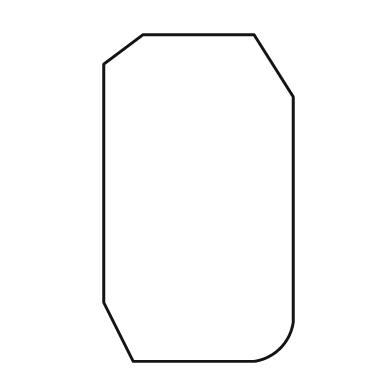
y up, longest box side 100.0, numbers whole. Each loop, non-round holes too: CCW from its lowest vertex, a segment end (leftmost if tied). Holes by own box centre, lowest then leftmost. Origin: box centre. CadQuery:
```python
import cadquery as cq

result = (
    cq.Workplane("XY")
    .moveTo(-20.0, -50.0)
    .lineTo(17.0, -50.0)
    .threePointArc((25.0, -46.0), (29.0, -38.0))
    .lineTo(29.0, 31.0)
    .lineTo(17.0, 50.0)
    .lineTo(-17.0, 50.0)
    .lineTo(-29.0, 41.0)
    .lineTo(-29.0, -32.0)
    .close()
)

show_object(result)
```